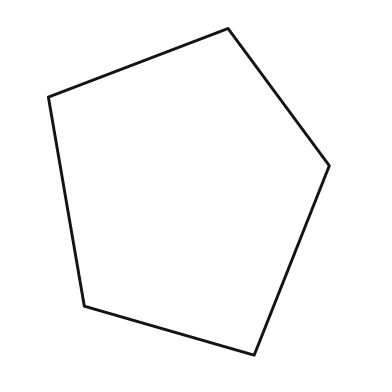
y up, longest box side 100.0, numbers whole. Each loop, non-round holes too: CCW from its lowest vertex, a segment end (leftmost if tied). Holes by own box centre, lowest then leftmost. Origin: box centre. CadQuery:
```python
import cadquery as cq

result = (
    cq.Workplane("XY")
    .moveTo(20.0, -50.0)
    .lineTo(43.0, 8.0)
    .lineTo(12.0, 50.0)
    .lineTo(-43.0, 29.0)
    .lineTo(-32.0, -35.0)
    .close()
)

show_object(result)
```